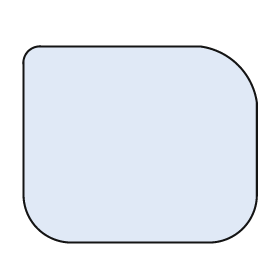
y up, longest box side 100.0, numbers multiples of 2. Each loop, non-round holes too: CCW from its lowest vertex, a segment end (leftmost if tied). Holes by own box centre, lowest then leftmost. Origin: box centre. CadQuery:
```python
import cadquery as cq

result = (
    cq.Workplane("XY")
    .moveTo(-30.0, -42.0)
    .lineTo(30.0, -42.0)
    .threePointArc((44.0, -36.0), (50.0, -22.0))
    .lineTo(50.0, 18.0)
    .threePointArc((42.0, 34.0), (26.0, 42.0))
    .lineTo(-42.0, 42.0)
    .threePointArc((-48.0, 40.0), (-50.0, 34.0))
    .lineTo(-50.0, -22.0)
    .threePointArc((-44.0, -36.0), (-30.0, -42.0))
    .close()
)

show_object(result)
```